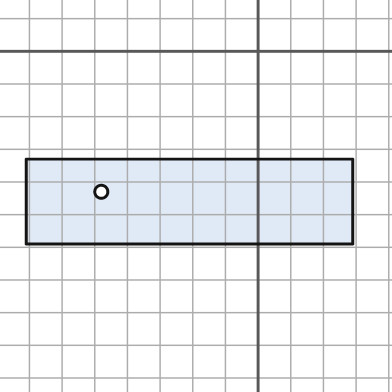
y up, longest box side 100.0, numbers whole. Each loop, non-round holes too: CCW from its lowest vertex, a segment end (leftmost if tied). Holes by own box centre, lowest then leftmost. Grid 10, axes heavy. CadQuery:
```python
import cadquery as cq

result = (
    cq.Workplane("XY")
    .moveTo(-71.0, -59.0)
    .lineTo(29.0, -59.0)
    .lineTo(29.0, -33.0)
    .lineTo(-71.0, -33.0)
    .close()
    .moveTo(-48.0, -43.0)
    .circle(2.0)
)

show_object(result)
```